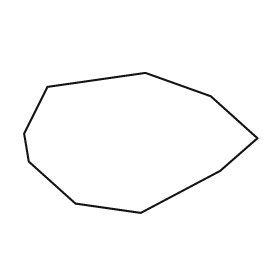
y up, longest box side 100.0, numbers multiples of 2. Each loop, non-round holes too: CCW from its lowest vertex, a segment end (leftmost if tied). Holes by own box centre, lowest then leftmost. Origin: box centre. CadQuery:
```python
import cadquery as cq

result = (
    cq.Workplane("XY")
    .moveTo(0.0, -30.0)
    .lineTo(34.0, -12.0)
    .lineTo(50.0, 2.0)
    .lineTo(30.0, 20.0)
    .lineTo(2.0, 30.0)
    .lineTo(-40.0, 24.0)
    .lineTo(-50.0, 4.0)
    .lineTo(-48.0, -8.0)
    .lineTo(-28.0, -26.0)
    .close()
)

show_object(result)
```